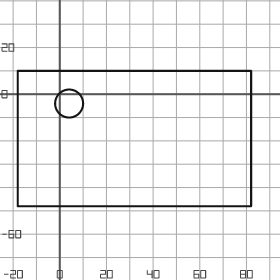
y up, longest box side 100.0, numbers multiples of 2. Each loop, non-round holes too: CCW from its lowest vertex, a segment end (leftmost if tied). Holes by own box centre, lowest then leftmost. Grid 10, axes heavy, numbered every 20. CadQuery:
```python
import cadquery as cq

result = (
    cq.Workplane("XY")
    .moveTo(-18.0, -48.0)
    .lineTo(82.0, -48.0)
    .lineTo(82.0, 10.0)
    .lineTo(-18.0, 10.0)
    .close()
    .moveTo(4.0, -4.0)
    .circle(6.0)
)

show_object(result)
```